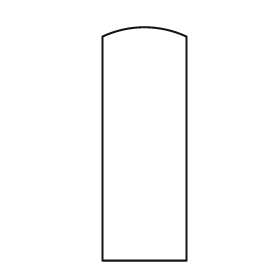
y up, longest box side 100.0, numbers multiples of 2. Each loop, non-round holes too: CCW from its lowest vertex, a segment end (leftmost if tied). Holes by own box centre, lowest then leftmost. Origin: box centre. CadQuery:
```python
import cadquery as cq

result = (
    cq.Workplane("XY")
    .moveTo(-18.0, -50.0)
    .lineTo(18.0, -50.0)
    .lineTo(18.0, 46.0)
    .threePointArc((0.0, 50.0), (-18.0, 46.0))
    .close()
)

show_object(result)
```